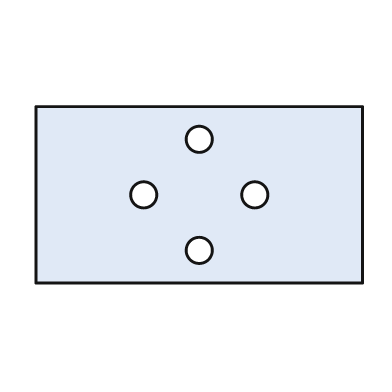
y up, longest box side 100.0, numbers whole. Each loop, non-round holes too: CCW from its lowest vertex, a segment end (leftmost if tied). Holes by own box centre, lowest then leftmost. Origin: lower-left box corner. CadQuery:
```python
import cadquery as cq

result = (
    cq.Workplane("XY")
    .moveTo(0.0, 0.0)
    .lineTo(100.0, 0.0)
    .lineTo(100.0, 54.0)
    .lineTo(0.0, 54.0)
    .close()
    .moveTo(50.0, 10.0)
    .circle(4.0)
    .moveTo(33.0, 27.0)
    .circle(4.0)
    .moveTo(67.0, 27.0)
    .circle(4.0)
    .moveTo(50.0, 44.0)
    .circle(4.0)
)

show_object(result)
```